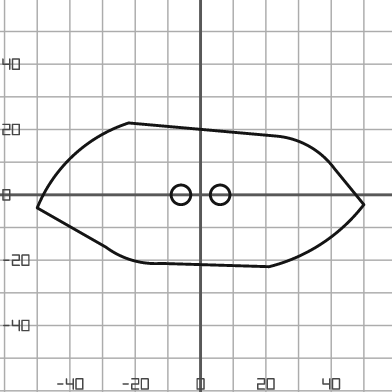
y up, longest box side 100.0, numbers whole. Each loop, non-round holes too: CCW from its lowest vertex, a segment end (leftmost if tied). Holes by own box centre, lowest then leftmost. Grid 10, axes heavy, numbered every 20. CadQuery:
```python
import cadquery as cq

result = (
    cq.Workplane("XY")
    .moveTo(21.0, -22.0)
    .threePointArc((37.0, -15.0), (50.0, -3.0))
    .lineTo(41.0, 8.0)
    .threePointArc((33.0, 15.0), (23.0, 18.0))
    .lineTo(-22.0, 22.0)
    .threePointArc((-39.0, 12.0), (-50.0, -4.0))
    .lineTo(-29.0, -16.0)
    .threePointArc((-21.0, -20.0), (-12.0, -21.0))
    .close()
    .moveTo(-6.0, 0.0)
    .circle(3.0)
    .moveTo(6.0, 0.0)
    .circle(3.0)
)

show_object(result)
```